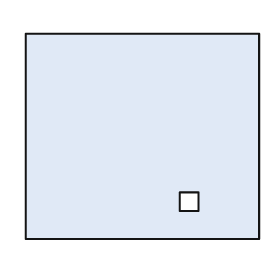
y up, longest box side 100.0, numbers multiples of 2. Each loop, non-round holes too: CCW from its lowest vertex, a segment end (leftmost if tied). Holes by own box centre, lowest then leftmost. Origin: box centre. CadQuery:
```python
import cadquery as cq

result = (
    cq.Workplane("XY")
    .moveTo(-50.0, -44.0)
    .lineTo(50.0, -44.0)
    .lineTo(50.0, 44.0)
    .lineTo(-50.0, 44.0)
    .close()
    .moveTo(16.0, -32.0)
    .lineTo(24.0, -32.0)
    .lineTo(24.0, -24.0)
    .lineTo(16.0, -24.0)
    .close()
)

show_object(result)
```